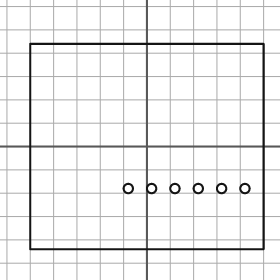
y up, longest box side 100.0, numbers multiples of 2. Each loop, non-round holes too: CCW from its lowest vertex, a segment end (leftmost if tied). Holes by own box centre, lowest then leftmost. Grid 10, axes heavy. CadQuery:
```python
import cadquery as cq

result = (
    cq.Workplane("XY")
    .moveTo(-50.0, -44.0)
    .lineTo(50.0, -44.0)
    .lineTo(50.0, 44.0)
    .lineTo(-50.0, 44.0)
    .close()
    .moveTo(-8.0, -18.0)
    .circle(2.0)
    .moveTo(2.0, -18.0)
    .circle(2.0)
    .moveTo(12.0, -18.0)
    .circle(2.0)
    .moveTo(22.0, -18.0)
    .circle(2.0)
    .moveTo(32.0, -18.0)
    .circle(2.0)
    .moveTo(42.0, -18.0)
    .circle(2.0)
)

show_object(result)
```